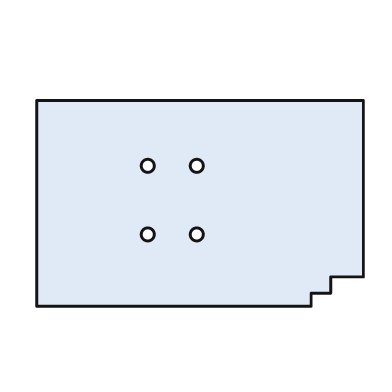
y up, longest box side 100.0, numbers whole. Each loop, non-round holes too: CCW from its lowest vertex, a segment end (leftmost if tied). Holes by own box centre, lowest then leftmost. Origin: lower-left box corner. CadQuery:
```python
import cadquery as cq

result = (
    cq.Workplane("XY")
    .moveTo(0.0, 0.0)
    .lineTo(84.0, 0.0)
    .lineTo(84.0, 4.0)
    .lineTo(90.0, 4.0)
    .lineTo(90.0, 9.0)
    .lineTo(100.0, 9.0)
    .lineTo(100.0, 63.0)
    .lineTo(0.0, 63.0)
    .close()
    .moveTo(34.0, 22.0)
    .circle(2.0)
    .moveTo(49.0, 22.0)
    .circle(2.0)
    .moveTo(34.0, 43.0)
    .circle(2.0)
    .moveTo(49.0, 43.0)
    .circle(2.0)
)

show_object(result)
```